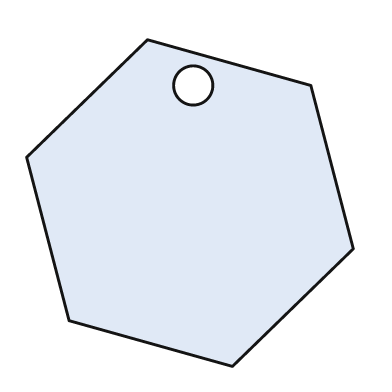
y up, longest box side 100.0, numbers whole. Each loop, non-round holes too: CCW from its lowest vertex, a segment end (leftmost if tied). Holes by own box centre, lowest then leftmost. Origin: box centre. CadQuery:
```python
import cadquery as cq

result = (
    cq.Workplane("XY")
    .moveTo(13.0, -50.0)
    .lineTo(50.0, -14.0)
    .lineTo(37.0, 36.0)
    .lineTo(-13.0, 50.0)
    .lineTo(-50.0, 14.0)
    .lineTo(-37.0, -36.0)
    .close()
    .moveTo(1.0, 36.0)
    .circle(6.0)
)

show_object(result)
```